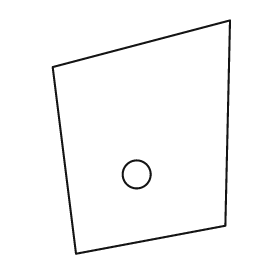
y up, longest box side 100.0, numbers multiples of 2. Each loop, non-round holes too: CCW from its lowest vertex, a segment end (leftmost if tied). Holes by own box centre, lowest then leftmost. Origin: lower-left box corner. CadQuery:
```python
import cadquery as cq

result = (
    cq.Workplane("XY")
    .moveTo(10.0, 0.0)
    .lineTo(74.0, 12.0)
    .lineTo(76.0, 100.0)
    .lineTo(0.0, 80.0)
    .close()
    .moveTo(36.0, 34.0)
    .circle(6.0)
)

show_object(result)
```